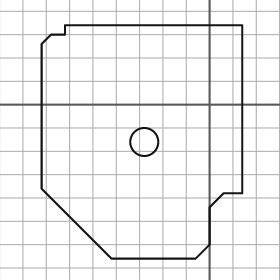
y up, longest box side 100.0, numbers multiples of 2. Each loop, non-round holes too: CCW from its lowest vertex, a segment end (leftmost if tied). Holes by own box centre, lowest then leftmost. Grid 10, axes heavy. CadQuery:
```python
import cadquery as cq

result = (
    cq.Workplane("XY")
    .moveTo(-42.0, -66.0)
    .lineTo(-6.0, -66.0)
    .lineTo(0.0, -60.0)
    .lineTo(0.0, -44.0)
    .lineTo(6.0, -38.0)
    .lineTo(14.0, -38.0)
    .lineTo(14.0, 34.0)
    .lineTo(-62.0, 34.0)
    .lineTo(-62.0, 30.0)
    .lineTo(-68.0, 30.0)
    .lineTo(-72.0, 26.0)
    .lineTo(-72.0, -36.0)
    .close()
    .moveTo(-28.0, -16.0)
    .circle(6.0)
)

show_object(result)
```